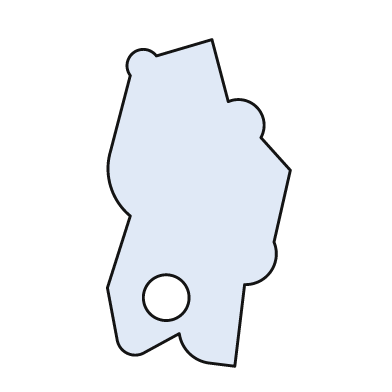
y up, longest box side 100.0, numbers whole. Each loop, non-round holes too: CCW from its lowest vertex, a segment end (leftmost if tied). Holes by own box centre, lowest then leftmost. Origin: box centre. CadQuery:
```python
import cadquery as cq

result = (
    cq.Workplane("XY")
    .moveTo(11.0, -50.0)
    .lineTo(14.0, -25.0)
    .threePointArc((22.0, -21.0), (23.0, -12.0))
    .lineTo(28.0, 10.0)
    .lineTo(19.0, 20.0)
    .threePointArc((18.0, 29.0), (9.0, 31.0))
    .lineTo(4.0, 50.0)
    .lineTo(-13.0, 45.0)
    .threePointArc((-20.0, 46.0), (-21.0, 39.0))
    .lineTo(-27.0, 16.0)
    .threePointArc((-27.0, 5.0), (-21.0, -4.0))
    .lineTo(-28.0, -26.0)
    .lineTo(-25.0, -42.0)
    .threePointArc((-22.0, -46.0), (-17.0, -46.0))
    .lineTo(-6.0, -40.0)
    .threePointArc((-3.0, -46.0), (3.0, -49.0))
    .close()
    .moveTo(-10.0, -29.0)
    .circle(7.0)
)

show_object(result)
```